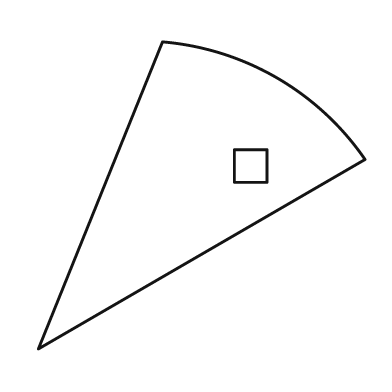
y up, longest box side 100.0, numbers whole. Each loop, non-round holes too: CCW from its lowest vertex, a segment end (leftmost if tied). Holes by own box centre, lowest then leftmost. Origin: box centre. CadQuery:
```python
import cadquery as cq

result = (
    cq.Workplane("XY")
    .moveTo(-50.0, -47.0)
    .lineTo(50.0, 11.0)
    .threePointArc((23.0, 36.0), (-12.0, 47.0))
    .close()
    .moveTo(10.0, 4.0)
    .lineTo(20.0, 4.0)
    .lineTo(20.0, 14.0)
    .lineTo(10.0, 14.0)
    .close()
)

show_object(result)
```